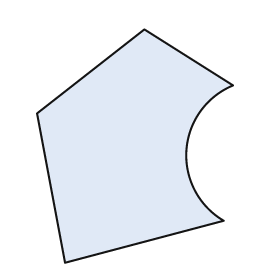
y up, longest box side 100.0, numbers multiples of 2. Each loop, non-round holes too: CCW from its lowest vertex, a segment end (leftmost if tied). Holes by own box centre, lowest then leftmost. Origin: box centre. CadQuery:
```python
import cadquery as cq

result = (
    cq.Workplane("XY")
    .moveTo(-30.0, -50.0)
    .lineTo(38.0, -32.0)
    .threePointArc((22.0, -2.0), (42.0, 26.0))
    .lineTo(4.0, 50.0)
    .lineTo(-42.0, 14.0)
    .close()
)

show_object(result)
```